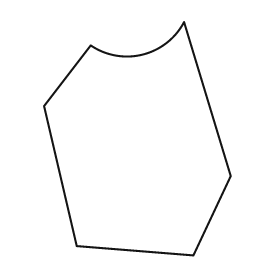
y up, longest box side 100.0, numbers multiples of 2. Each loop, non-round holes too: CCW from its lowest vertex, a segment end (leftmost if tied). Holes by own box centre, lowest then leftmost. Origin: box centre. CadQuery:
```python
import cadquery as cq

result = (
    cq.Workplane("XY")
    .moveTo(24.0, -50.0)
    .lineTo(40.0, -16.0)
    .lineTo(20.0, 50.0)
    .threePointArc((2.0, 36.0), (-20.0, 40.0))
    .lineTo(-40.0, 14.0)
    .lineTo(-26.0, -46.0)
    .close()
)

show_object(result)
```